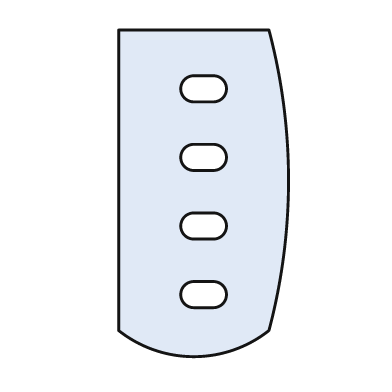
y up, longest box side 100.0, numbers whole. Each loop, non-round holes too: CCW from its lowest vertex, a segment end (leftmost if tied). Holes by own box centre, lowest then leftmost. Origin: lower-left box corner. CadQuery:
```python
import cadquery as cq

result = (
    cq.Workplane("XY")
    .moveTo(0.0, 8.0)
    .threePointArc((23.0, 0.0), (46.0, 8.0))
    .threePointArc((52.0, 54.0), (46.0, 100.0))
    .lineTo(0.0, 100.0)
    .close()
    .moveTo(23.0, 15.0)
    .lineTo(29.0, 15.0)
    .threePointArc((33.0, 19.0), (29.0, 23.0))
    .lineTo(23.0, 23.0)
    .threePointArc((19.0, 19.0), (23.0, 15.0))
    .close()
    .moveTo(23.0, 36.0)
    .lineTo(29.0, 36.0)
    .threePointArc((33.0, 40.0), (29.0, 44.0))
    .lineTo(23.0, 44.0)
    .threePointArc((19.0, 40.0), (23.0, 36.0))
    .close()
    .moveTo(23.0, 57.0)
    .lineTo(29.0, 57.0)
    .threePointArc((33.0, 61.0), (29.0, 65.0))
    .lineTo(23.0, 65.0)
    .threePointArc((19.0, 61.0), (23.0, 57.0))
    .close()
    .moveTo(23.0, 78.0)
    .lineTo(29.0, 78.0)
    .threePointArc((33.0, 82.0), (29.0, 86.0))
    .lineTo(23.0, 86.0)
    .threePointArc((19.0, 82.0), (23.0, 78.0))
    .close()
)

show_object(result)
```